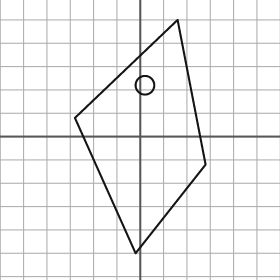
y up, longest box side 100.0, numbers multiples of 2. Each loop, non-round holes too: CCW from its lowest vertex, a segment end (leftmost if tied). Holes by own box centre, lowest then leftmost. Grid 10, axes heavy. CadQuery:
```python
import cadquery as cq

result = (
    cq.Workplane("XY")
    .moveTo(-2.0, -50.0)
    .lineTo(28.0, -12.0)
    .lineTo(16.0, 50.0)
    .lineTo(-28.0, 8.0)
    .close()
    .moveTo(2.0, 22.0)
    .circle(4.0)
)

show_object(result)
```